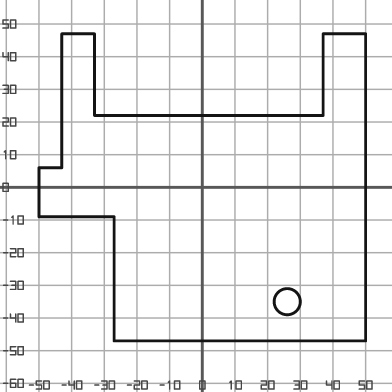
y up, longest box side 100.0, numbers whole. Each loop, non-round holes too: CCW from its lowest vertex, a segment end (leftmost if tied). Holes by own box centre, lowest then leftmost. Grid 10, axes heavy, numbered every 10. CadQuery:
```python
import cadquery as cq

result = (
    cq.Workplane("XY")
    .moveTo(-27.0, -47.0)
    .lineTo(50.0, -47.0)
    .lineTo(50.0, 47.0)
    .lineTo(37.0, 47.0)
    .lineTo(37.0, 22.0)
    .lineTo(-33.0, 22.0)
    .lineTo(-33.0, 47.0)
    .lineTo(-43.0, 47.0)
    .lineTo(-43.0, 6.0)
    .lineTo(-50.0, 6.0)
    .lineTo(-50.0, -9.0)
    .lineTo(-27.0, -9.0)
    .close()
    .moveTo(26.0, -35.0)
    .circle(4.0)
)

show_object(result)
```